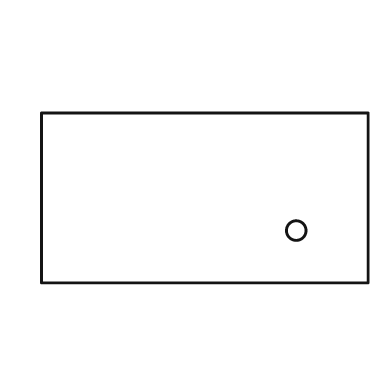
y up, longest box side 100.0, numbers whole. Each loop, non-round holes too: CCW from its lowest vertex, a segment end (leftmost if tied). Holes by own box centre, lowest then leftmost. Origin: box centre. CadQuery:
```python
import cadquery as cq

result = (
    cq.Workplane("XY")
    .moveTo(-50.0, -26.0)
    .lineTo(50.0, -26.0)
    .lineTo(50.0, 26.0)
    .lineTo(-50.0, 26.0)
    .close()
    .moveTo(28.0, -10.0)
    .circle(3.0)
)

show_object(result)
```